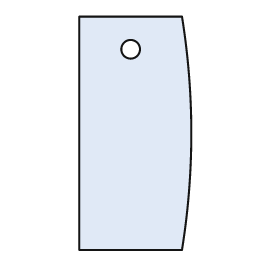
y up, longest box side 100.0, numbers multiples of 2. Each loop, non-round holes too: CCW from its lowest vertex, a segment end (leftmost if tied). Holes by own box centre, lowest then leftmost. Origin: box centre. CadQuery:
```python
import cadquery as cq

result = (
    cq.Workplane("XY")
    .moveTo(-24.0, -50.0)
    .lineTo(20.0, -50.0)
    .threePointArc((24.0, 0.0), (20.0, 50.0))
    .lineTo(-24.0, 50.0)
    .close()
    .moveTo(-2.0, 36.0)
    .circle(4.0)
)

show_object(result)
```